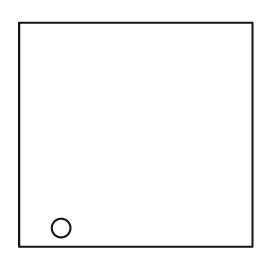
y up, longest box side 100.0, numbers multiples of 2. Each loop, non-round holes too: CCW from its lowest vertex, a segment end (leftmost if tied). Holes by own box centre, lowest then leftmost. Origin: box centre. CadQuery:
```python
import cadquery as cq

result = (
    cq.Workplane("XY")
    .moveTo(-50.0, -48.0)
    .lineTo(50.0, -48.0)
    .lineTo(50.0, 48.0)
    .lineTo(-50.0, 48.0)
    .close()
    .moveTo(-32.0, -40.0)
    .circle(4.0)
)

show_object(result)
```